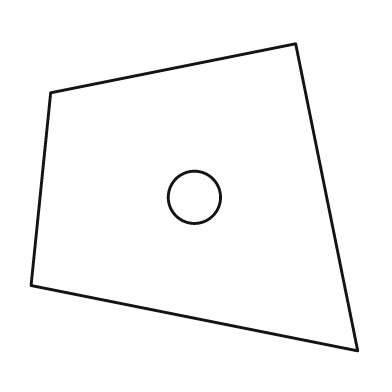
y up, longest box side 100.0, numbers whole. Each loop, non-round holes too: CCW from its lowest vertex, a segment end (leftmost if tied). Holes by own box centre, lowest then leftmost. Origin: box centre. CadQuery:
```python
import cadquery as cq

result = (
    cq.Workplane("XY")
    .moveTo(50.0, -47.0)
    .lineTo(31.0, 47.0)
    .lineTo(-44.0, 32.0)
    .lineTo(-50.0, -27.0)
    .close()
    .moveTo(0.0, 0.0)
    .circle(8.0)
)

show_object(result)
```